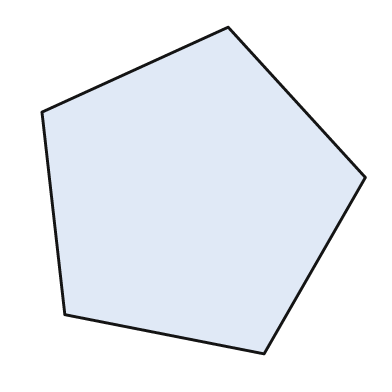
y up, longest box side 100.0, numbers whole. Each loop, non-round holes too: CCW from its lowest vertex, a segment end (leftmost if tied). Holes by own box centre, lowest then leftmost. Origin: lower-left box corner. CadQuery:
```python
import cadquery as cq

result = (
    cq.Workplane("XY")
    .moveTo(68.0, 0.0)
    .lineTo(99.0, 54.0)
    .lineTo(57.0, 100.0)
    .lineTo(0.0, 74.0)
    .lineTo(7.0, 12.0)
    .close()
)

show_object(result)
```